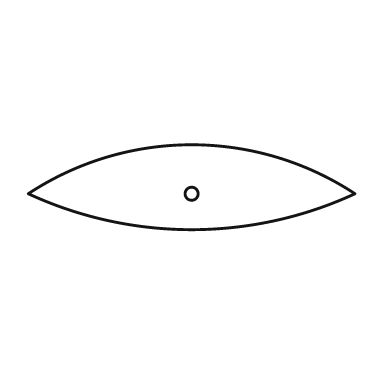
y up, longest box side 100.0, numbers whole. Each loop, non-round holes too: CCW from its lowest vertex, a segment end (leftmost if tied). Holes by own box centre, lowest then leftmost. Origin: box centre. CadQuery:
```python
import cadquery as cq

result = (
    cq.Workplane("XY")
    .moveTo(-50.0, -2.0)
    .threePointArc((0.0, -13.0), (50.0, -2.0))
    .threePointArc((0.0, 13.0), (-50.0, -2.0))
    .close()
    .moveTo(0.0, -2.0)
    .circle(2.0)
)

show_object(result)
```